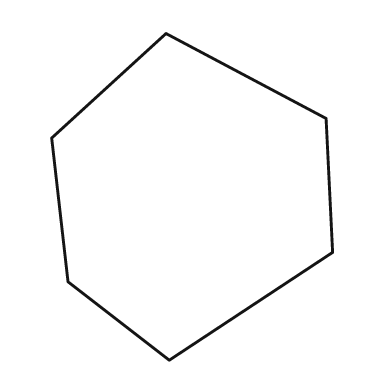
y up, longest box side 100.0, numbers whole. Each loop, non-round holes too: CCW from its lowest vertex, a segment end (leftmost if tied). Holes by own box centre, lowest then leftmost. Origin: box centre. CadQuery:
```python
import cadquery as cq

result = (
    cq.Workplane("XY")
    .moveTo(-7.0, -50.0)
    .lineTo(43.0, -17.0)
    .lineTo(41.0, 24.0)
    .lineTo(-8.0, 50.0)
    .lineTo(-43.0, 18.0)
    .lineTo(-38.0, -26.0)
    .close()
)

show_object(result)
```